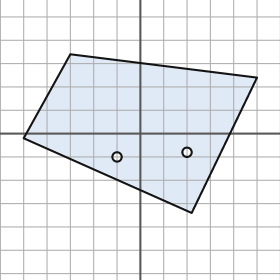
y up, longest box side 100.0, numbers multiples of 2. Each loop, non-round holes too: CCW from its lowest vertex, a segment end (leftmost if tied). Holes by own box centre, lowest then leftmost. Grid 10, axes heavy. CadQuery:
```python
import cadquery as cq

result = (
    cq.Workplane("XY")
    .moveTo(22.0, -34.0)
    .lineTo(50.0, 24.0)
    .lineTo(-30.0, 34.0)
    .lineTo(-50.0, -2.0)
    .close()
    .moveTo(-10.0, -10.0)
    .circle(2.0)
    .moveTo(20.0, -8.0)
    .circle(2.0)
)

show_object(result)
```